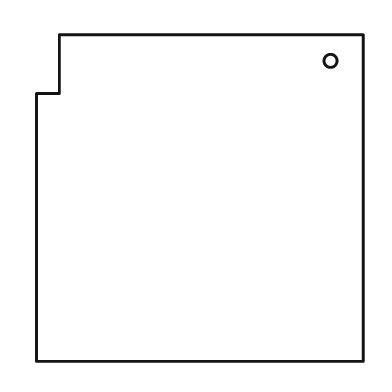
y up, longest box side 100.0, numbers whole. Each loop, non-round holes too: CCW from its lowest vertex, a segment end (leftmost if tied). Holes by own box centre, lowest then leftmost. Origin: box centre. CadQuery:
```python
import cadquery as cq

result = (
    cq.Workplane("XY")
    .moveTo(-50.0, -50.0)
    .lineTo(50.0, -50.0)
    .lineTo(50.0, 50.0)
    .lineTo(-43.0, 50.0)
    .lineTo(-43.0, 32.0)
    .lineTo(-50.0, 32.0)
    .close()
    .moveTo(40.0, 42.0)
    .circle(2.0)
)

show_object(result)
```